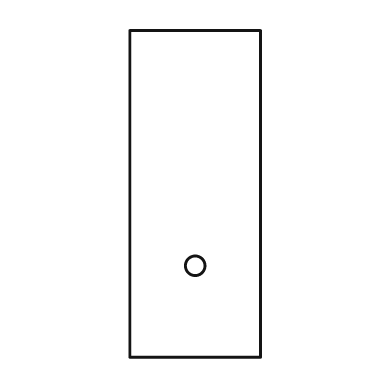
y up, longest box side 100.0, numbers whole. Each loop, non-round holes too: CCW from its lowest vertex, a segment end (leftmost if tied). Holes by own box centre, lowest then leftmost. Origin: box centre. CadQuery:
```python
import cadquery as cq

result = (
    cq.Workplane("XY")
    .moveTo(-20.0, -50.0)
    .lineTo(20.0, -50.0)
    .lineTo(20.0, 50.0)
    .lineTo(-20.0, 50.0)
    .close()
    .moveTo(0.0, -22.0)
    .circle(3.0)
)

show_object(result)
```